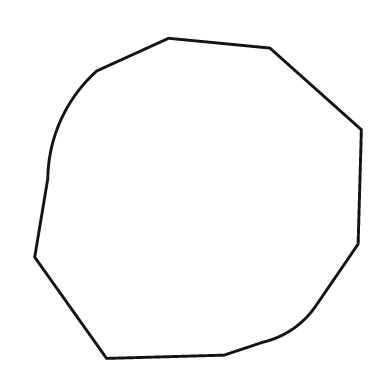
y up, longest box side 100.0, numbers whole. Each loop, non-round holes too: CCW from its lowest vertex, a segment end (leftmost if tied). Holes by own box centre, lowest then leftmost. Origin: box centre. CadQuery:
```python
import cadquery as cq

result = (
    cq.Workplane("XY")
    .moveTo(-28.0, -49.0)
    .lineTo(8.0, -48.0)
    .lineTo(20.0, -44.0)
    .threePointArc((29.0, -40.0), (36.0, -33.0))
    .lineTo(49.0, -14.0)
    .lineTo(50.0, 21.0)
    .lineTo(22.0, 46.0)
    .lineTo(-9.0, 49.0)
    .lineTo(-31.0, 39.0)
    .threePointArc((-42.0, 24.0), (-46.0, 6.0))
    .lineTo(-50.0, -18.0)
    .close()
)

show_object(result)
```